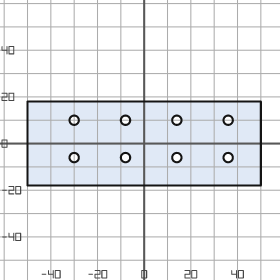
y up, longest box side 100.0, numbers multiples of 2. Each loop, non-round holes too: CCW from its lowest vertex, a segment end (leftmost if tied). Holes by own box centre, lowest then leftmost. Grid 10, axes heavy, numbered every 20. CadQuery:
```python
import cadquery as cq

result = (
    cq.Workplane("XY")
    .moveTo(-50.0, -18.0)
    .lineTo(50.0, -18.0)
    .lineTo(50.0, 18.0)
    .lineTo(-50.0, 18.0)
    .close()
    .moveTo(-30.0, -6.0)
    .circle(2.0)
    .moveTo(-8.0, -6.0)
    .circle(2.0)
    .moveTo(14.0, -6.0)
    .circle(2.0)
    .moveTo(36.0, -6.0)
    .circle(2.0)
    .moveTo(-30.0, 10.0)
    .circle(2.0)
    .moveTo(-8.0, 10.0)
    .circle(2.0)
    .moveTo(14.0, 10.0)
    .circle(2.0)
    .moveTo(36.0, 10.0)
    .circle(2.0)
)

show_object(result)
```